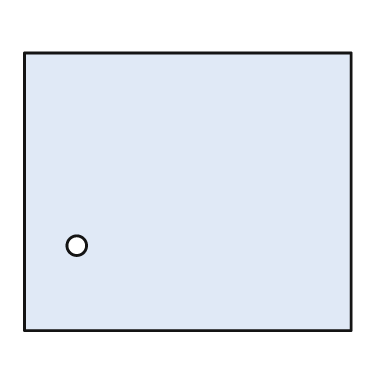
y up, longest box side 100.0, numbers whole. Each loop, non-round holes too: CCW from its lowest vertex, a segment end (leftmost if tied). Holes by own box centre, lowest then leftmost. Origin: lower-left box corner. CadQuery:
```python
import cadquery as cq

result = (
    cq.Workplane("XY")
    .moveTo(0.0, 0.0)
    .lineTo(100.0, 0.0)
    .lineTo(100.0, 85.0)
    .lineTo(0.0, 85.0)
    .close()
    .moveTo(16.0, 26.0)
    .circle(3.0)
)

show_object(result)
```